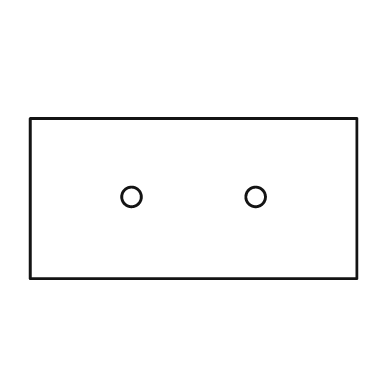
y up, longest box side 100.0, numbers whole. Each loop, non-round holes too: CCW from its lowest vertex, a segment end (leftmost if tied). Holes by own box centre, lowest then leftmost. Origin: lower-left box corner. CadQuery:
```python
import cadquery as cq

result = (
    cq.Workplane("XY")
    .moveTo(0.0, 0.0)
    .lineTo(100.0, 0.0)
    .lineTo(100.0, 49.0)
    .lineTo(0.0, 49.0)
    .close()
    .moveTo(31.0, 25.0)
    .circle(3.0)
    .moveTo(69.0, 25.0)
    .circle(3.0)
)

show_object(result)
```